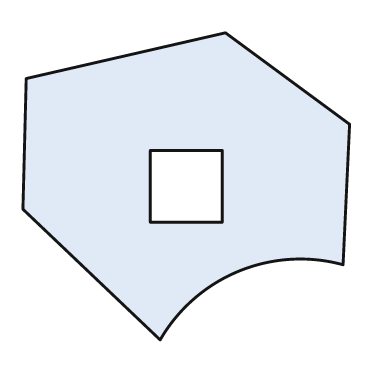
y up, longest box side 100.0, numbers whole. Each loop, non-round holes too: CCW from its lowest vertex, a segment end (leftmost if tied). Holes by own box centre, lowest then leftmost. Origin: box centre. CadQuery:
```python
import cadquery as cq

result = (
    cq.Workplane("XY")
    .moveTo(-8.0, -47.0)
    .threePointArc((16.0, -26.0), (48.0, -24.0))
    .lineTo(50.0, 19.0)
    .lineTo(12.0, 47.0)
    .lineTo(-49.0, 33.0)
    .lineTo(-50.0, -7.0)
    .close()
    .moveTo(-11.0, -11.0)
    .lineTo(11.0, -11.0)
    .lineTo(11.0, 11.0)
    .lineTo(-11.0, 11.0)
    .close()
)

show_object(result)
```